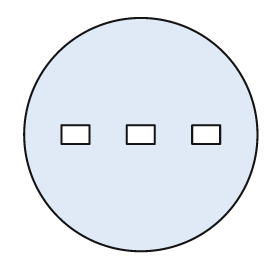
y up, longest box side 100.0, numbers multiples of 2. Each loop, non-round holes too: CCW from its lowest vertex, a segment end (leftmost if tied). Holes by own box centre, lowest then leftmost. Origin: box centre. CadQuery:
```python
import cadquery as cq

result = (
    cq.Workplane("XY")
    .moveTo(0.0, 0.0)
    .circle(50.0)
    .moveTo(-34.0, -4.0)
    .lineTo(-22.0, -4.0)
    .lineTo(-22.0, 4.0)
    .lineTo(-34.0, 4.0)
    .close()
    .moveTo(-6.0, -4.0)
    .lineTo(6.0, -4.0)
    .lineTo(6.0, 4.0)
    .lineTo(-6.0, 4.0)
    .close()
    .moveTo(22.0, -4.0)
    .lineTo(34.0, -4.0)
    .lineTo(34.0, 4.0)
    .lineTo(22.0, 4.0)
    .close()
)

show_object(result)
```